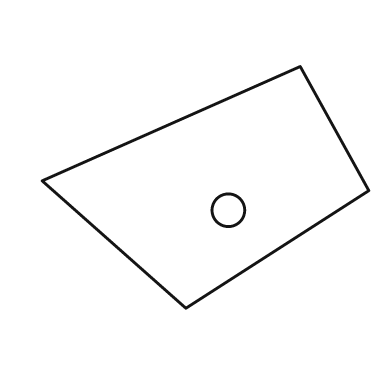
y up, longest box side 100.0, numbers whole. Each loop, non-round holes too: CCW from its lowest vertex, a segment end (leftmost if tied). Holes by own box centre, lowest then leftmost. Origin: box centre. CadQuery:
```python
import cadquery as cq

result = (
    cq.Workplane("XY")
    .moveTo(-6.0, -37.0)
    .lineTo(50.0, -1.0)
    .lineTo(29.0, 37.0)
    .lineTo(-50.0, 2.0)
    .close()
    .moveTo(7.0, -7.0)
    .circle(5.0)
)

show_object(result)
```